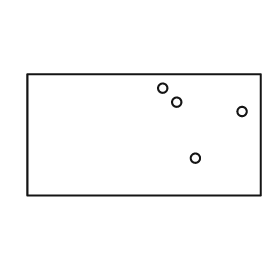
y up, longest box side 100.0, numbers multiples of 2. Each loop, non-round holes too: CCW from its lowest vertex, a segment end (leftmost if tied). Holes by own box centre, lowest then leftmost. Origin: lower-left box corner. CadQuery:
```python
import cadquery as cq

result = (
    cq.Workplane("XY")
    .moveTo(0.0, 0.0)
    .lineTo(100.0, 0.0)
    .lineTo(100.0, 52.0)
    .lineTo(0.0, 52.0)
    .close()
    .moveTo(72.0, 16.0)
    .circle(2.0)
    .moveTo(92.0, 36.0)
    .circle(2.0)
    .moveTo(64.0, 40.0)
    .circle(2.0)
    .moveTo(58.0, 46.0)
    .circle(2.0)
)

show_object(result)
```